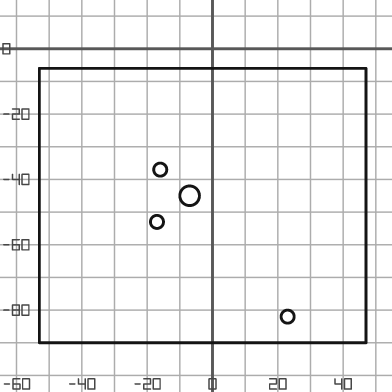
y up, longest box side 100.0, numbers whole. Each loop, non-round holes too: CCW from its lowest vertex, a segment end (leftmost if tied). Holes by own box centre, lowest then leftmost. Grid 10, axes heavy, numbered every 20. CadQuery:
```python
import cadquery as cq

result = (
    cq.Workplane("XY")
    .moveTo(-53.0, -90.0)
    .lineTo(47.0, -90.0)
    .lineTo(47.0, -6.0)
    .lineTo(-53.0, -6.0)
    .close()
    .moveTo(23.0, -82.0)
    .circle(2.0)
    .moveTo(-17.0, -53.0)
    .circle(2.0)
    .moveTo(-7.0, -45.0)
    .circle(3.0)
    .moveTo(-16.0, -37.0)
    .circle(2.0)
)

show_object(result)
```